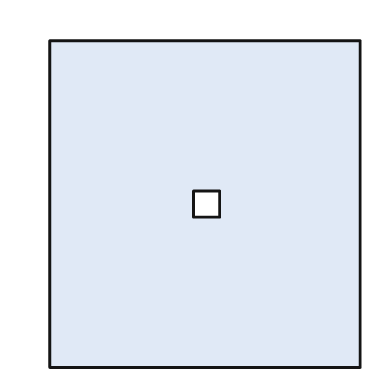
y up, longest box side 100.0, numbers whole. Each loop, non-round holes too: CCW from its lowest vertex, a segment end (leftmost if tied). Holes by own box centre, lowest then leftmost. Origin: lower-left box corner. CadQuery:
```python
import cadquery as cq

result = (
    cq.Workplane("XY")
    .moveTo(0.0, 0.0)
    .lineTo(95.0, 0.0)
    .lineTo(95.0, 100.0)
    .lineTo(0.0, 100.0)
    .close()
    .moveTo(44.0, 46.0)
    .lineTo(52.0, 46.0)
    .lineTo(52.0, 54.0)
    .lineTo(44.0, 54.0)
    .close()
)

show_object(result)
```